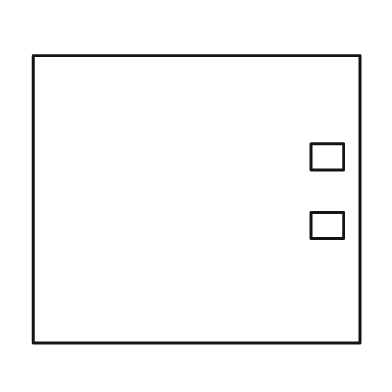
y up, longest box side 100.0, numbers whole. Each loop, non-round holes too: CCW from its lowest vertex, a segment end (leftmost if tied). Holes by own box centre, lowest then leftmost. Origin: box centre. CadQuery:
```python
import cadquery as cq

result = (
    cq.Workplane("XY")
    .moveTo(-50.0, -44.0)
    .lineTo(50.0, -44.0)
    .lineTo(50.0, 44.0)
    .lineTo(-50.0, 44.0)
    .close()
    .moveTo(35.0, -12.0)
    .lineTo(45.0, -12.0)
    .lineTo(45.0, -4.0)
    .lineTo(35.0, -4.0)
    .close()
    .moveTo(35.0, 9.0)
    .lineTo(45.0, 9.0)
    .lineTo(45.0, 17.0)
    .lineTo(35.0, 17.0)
    .close()
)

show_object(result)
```